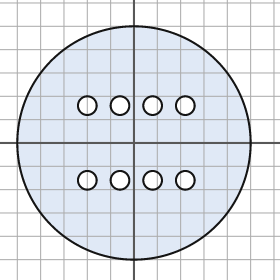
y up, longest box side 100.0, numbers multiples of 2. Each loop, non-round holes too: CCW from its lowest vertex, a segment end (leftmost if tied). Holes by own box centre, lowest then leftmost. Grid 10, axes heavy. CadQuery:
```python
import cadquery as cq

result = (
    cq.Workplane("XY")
    .moveTo(0.0, 0.0)
    .circle(50.0)
    .moveTo(-20.0, -16.0)
    .circle(4.0)
    .moveTo(-6.0, -16.0)
    .circle(4.0)
    .moveTo(8.0, -16.0)
    .circle(4.0)
    .moveTo(22.0, -16.0)
    .circle(4.0)
    .moveTo(-20.0, 16.0)
    .circle(4.0)
    .moveTo(-6.0, 16.0)
    .circle(4.0)
    .moveTo(8.0, 16.0)
    .circle(4.0)
    .moveTo(22.0, 16.0)
    .circle(4.0)
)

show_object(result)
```